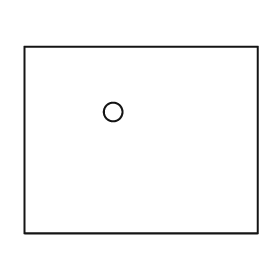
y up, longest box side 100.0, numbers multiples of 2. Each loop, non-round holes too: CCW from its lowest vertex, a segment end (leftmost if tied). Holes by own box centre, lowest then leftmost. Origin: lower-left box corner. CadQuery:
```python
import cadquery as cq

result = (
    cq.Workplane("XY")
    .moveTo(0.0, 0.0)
    .lineTo(100.0, 0.0)
    .lineTo(100.0, 80.0)
    .lineTo(0.0, 80.0)
    .close()
    .moveTo(38.0, 52.0)
    .circle(4.0)
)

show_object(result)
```